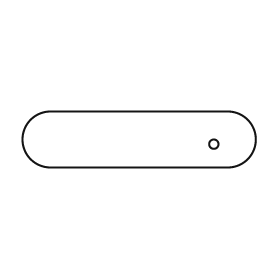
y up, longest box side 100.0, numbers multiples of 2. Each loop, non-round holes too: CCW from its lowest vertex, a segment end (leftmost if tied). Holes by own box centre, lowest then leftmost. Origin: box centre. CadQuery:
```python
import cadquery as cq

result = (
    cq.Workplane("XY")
    .moveTo(-38.0, -12.0)
    .lineTo(38.0, -12.0)
    .threePointArc((50.0, 0.0), (38.0, 12.0))
    .lineTo(-38.0, 12.0)
    .threePointArc((-50.0, 0.0), (-38.0, -12.0))
    .close()
    .moveTo(32.0, -2.0)
    .circle(2.0)
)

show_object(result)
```